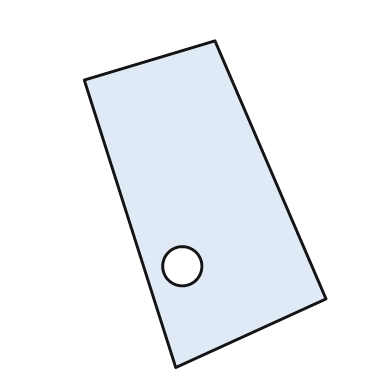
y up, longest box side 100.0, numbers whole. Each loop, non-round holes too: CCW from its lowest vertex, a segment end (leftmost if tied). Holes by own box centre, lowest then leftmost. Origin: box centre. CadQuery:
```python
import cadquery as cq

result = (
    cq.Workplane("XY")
    .moveTo(-9.0, -50.0)
    .lineTo(37.0, -29.0)
    .lineTo(3.0, 50.0)
    .lineTo(-37.0, 38.0)
    .close()
    .moveTo(-7.0, -19.0)
    .circle(6.0)
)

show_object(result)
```